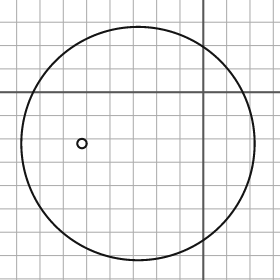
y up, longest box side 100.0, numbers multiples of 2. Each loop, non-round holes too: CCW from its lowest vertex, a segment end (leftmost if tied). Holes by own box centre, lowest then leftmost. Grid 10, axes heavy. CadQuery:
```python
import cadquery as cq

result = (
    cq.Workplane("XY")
    .moveTo(-28.0, -22.0)
    .circle(50.0)
    .moveTo(-52.0, -22.0)
    .circle(2.0)
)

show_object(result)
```